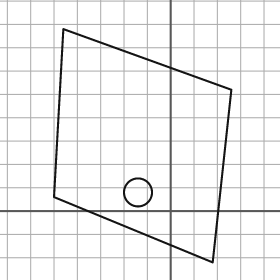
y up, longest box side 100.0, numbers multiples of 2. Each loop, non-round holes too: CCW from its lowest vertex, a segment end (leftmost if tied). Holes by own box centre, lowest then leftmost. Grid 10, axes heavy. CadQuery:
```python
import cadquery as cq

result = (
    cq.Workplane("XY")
    .moveTo(18.0, -22.0)
    .lineTo(26.0, 52.0)
    .lineTo(-46.0, 78.0)
    .lineTo(-50.0, 6.0)
    .close()
    .moveTo(-14.0, 8.0)
    .circle(6.0)
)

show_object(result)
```